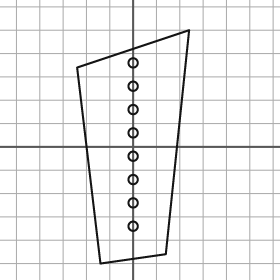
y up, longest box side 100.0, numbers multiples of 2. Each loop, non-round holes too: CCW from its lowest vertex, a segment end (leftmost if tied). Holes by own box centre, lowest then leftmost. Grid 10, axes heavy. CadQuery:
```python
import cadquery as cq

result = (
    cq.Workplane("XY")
    .moveTo(-14.0, -50.0)
    .lineTo(14.0, -46.0)
    .lineTo(24.0, 50.0)
    .lineTo(-24.0, 34.0)
    .close()
    .moveTo(0.0, -34.0)
    .circle(2.0)
    .moveTo(0.0, -24.0)
    .circle(2.0)
    .moveTo(0.0, -14.0)
    .circle(2.0)
    .moveTo(0.0, -4.0)
    .circle(2.0)
    .moveTo(0.0, 6.0)
    .circle(2.0)
    .moveTo(0.0, 16.0)
    .circle(2.0)
    .moveTo(0.0, 26.0)
    .circle(2.0)
    .moveTo(0.0, 36.0)
    .circle(2.0)
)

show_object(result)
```